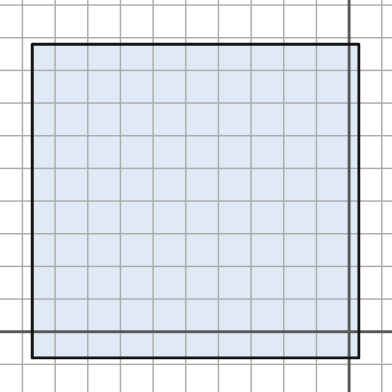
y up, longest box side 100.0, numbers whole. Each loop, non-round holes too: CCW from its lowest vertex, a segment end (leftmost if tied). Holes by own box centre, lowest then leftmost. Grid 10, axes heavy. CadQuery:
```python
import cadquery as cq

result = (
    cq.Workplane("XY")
    .moveTo(-97.0, -8.0)
    .lineTo(3.0, -8.0)
    .lineTo(3.0, 88.0)
    .lineTo(-97.0, 88.0)
    .close()
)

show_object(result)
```